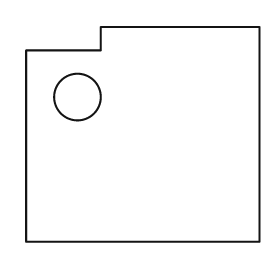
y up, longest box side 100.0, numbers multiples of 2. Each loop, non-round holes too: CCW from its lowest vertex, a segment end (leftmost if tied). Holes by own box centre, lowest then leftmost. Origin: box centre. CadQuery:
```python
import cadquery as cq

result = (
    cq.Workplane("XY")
    .moveTo(-50.0, -46.0)
    .lineTo(50.0, -46.0)
    .lineTo(50.0, 46.0)
    .lineTo(-18.0, 46.0)
    .lineTo(-18.0, 36.0)
    .lineTo(-50.0, 36.0)
    .close()
    .moveTo(-28.0, 16.0)
    .circle(10.0)
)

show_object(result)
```